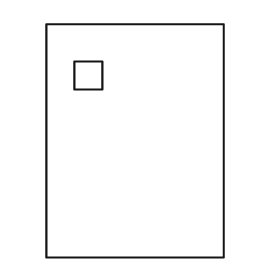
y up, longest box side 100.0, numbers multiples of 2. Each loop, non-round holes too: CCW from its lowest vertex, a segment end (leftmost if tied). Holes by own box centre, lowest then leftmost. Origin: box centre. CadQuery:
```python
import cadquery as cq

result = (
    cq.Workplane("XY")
    .moveTo(-38.0, -50.0)
    .lineTo(38.0, -50.0)
    .lineTo(38.0, 50.0)
    .lineTo(-38.0, 50.0)
    .close()
    .moveTo(-26.0, 22.0)
    .lineTo(-14.0, 22.0)
    .lineTo(-14.0, 34.0)
    .lineTo(-26.0, 34.0)
    .close()
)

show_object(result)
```